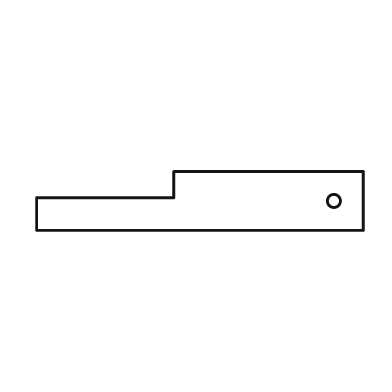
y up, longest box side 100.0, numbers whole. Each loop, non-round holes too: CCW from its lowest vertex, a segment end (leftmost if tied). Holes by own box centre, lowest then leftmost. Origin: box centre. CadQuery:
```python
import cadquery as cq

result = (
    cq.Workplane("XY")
    .moveTo(-50.0, -9.0)
    .lineTo(50.0, -9.0)
    .lineTo(50.0, 9.0)
    .lineTo(-8.0, 9.0)
    .lineTo(-8.0, 1.0)
    .lineTo(-50.0, 1.0)
    .close()
    .moveTo(41.0, 0.0)
    .circle(2.0)
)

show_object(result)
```